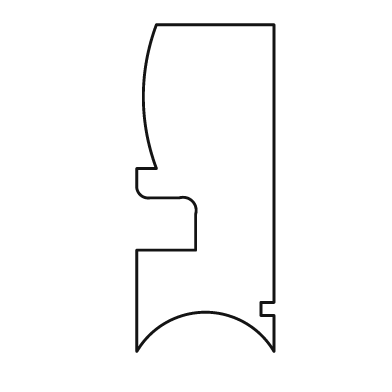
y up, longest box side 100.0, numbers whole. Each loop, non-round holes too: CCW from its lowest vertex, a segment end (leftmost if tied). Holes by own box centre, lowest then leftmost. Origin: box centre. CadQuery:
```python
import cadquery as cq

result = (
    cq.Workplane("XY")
    .moveTo(-21.0, -50.0)
    .threePointArc((0.0, -38.0), (21.0, -50.0))
    .lineTo(21.0, -39.0)
    .lineTo(17.0, -39.0)
    .lineTo(17.0, -35.0)
    .lineTo(21.0, -35.0)
    .lineTo(21.0, 50.0)
    .lineTo(-15.0, 50.0)
    .threePointArc((-19.0, 28.0), (-15.0, 6.0))
    .lineTo(-21.0, 6.0)
    .lineTo(-21.0, 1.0)
    .threePointArc((-20.0, -2.0), (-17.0, -3.0))
    .lineTo(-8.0, -3.0)
    .threePointArc((-4.0, -4.0), (-3.0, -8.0))
    .lineTo(-3.0, -19.0)
    .lineTo(-21.0, -19.0)
    .close()
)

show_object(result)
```